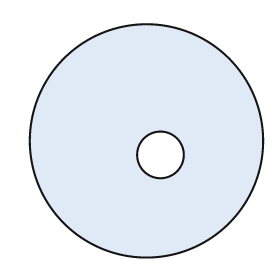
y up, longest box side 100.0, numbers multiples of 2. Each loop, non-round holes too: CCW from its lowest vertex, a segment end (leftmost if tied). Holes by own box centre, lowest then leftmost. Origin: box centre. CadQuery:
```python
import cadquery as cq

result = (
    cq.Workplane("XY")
    .moveTo(0.0, 0.0)
    .circle(50.0)
    .moveTo(6.0, -6.0)
    .circle(10.0)
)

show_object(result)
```